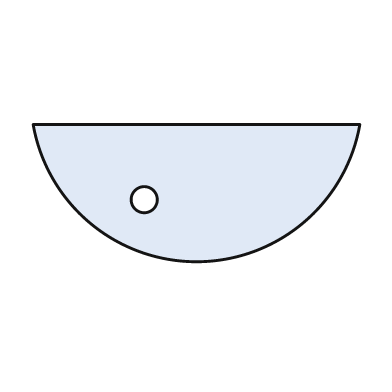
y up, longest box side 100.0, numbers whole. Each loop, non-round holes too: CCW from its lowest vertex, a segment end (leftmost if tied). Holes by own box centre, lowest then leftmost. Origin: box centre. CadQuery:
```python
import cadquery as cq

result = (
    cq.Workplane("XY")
    .moveTo(-50.0, 21.0)
    .threePointArc((0.0, -21.0), (50.0, 21.0))
    .close()
    .moveTo(-16.0, -2.0)
    .circle(4.0)
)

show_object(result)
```